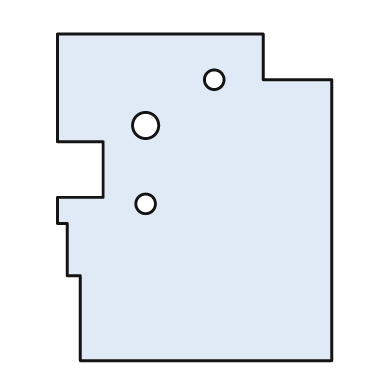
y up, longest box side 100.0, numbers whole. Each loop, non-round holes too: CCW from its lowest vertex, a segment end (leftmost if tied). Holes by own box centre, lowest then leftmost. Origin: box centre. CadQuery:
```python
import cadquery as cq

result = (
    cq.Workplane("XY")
    .moveTo(-35.0, -50.0)
    .lineTo(42.0, -50.0)
    .lineTo(42.0, 36.0)
    .lineTo(21.0, 36.0)
    .lineTo(21.0, 50.0)
    .lineTo(-42.0, 50.0)
    .lineTo(-42.0, 17.0)
    .lineTo(-28.0, 17.0)
    .lineTo(-28.0, 0.0)
    .lineTo(-42.0, 0.0)
    .lineTo(-42.0, -8.0)
    .lineTo(-39.0, -8.0)
    .lineTo(-39.0, -24.0)
    .lineTo(-35.0, -24.0)
    .close()
    .moveTo(-15.0, -2.0)
    .circle(3.0)
    .moveTo(-15.0, 22.0)
    .circle(4.0)
    .moveTo(6.0, 36.0)
    .circle(3.0)
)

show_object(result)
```